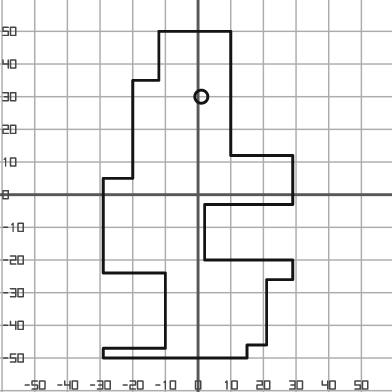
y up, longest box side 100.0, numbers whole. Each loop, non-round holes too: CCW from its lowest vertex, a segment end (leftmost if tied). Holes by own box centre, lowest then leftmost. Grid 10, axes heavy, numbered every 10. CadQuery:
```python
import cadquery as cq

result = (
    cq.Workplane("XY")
    .moveTo(-29.0, -50.0)
    .lineTo(15.0, -50.0)
    .lineTo(15.0, -46.0)
    .lineTo(21.0, -46.0)
    .lineTo(21.0, -26.0)
    .lineTo(29.0, -26.0)
    .lineTo(29.0, -20.0)
    .lineTo(2.0, -20.0)
    .lineTo(2.0, -3.0)
    .lineTo(29.0, -3.0)
    .lineTo(29.0, 12.0)
    .lineTo(10.0, 12.0)
    .lineTo(10.0, 50.0)
    .lineTo(-12.0, 50.0)
    .lineTo(-12.0, 35.0)
    .lineTo(-20.0, 35.0)
    .lineTo(-20.0, 5.0)
    .lineTo(-29.0, 5.0)
    .lineTo(-29.0, -24.0)
    .lineTo(-10.0, -24.0)
    .lineTo(-10.0, -47.0)
    .lineTo(-29.0, -47.0)
    .close()
    .moveTo(1.0, 30.0)
    .circle(2.0)
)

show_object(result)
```